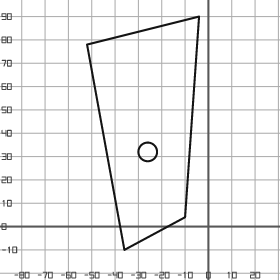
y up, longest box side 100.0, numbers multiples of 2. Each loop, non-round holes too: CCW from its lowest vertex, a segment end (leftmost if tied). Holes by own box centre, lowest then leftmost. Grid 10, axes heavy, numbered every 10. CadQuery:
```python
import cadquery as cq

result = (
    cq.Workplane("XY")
    .moveTo(-36.0, -10.0)
    .lineTo(-10.0, 4.0)
    .lineTo(-4.0, 90.0)
    .lineTo(-52.0, 78.0)
    .close()
    .moveTo(-26.0, 32.0)
    .circle(4.0)
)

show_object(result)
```